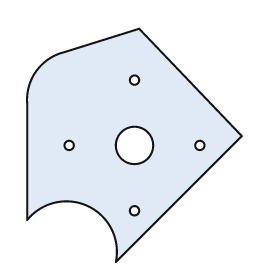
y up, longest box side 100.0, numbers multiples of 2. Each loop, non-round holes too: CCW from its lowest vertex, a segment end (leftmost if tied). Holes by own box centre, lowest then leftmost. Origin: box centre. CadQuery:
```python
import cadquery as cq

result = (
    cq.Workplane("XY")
    .moveTo(-8.0, -50.0)
    .lineTo(46.0, 4.0)
    .lineTo(2.0, 50.0)
    .lineTo(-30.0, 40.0)
    .threePointArc((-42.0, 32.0), (-46.0, 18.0))
    .lineTo(-46.0, -32.0)
    .threePointArc((-20.0, -26.0), (-8.0, -50.0))
    .close()
    .moveTo(0.0, -28.0)
    .circle(2.0)
    .moveTo(-28.0, 0.0)
    .circle(2.0)
    .moveTo(0.0, 0.0)
    .circle(8.0)
    .moveTo(28.0, 0.0)
    .circle(2.0)
    .moveTo(0.0, 28.0)
    .circle(2.0)
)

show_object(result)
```